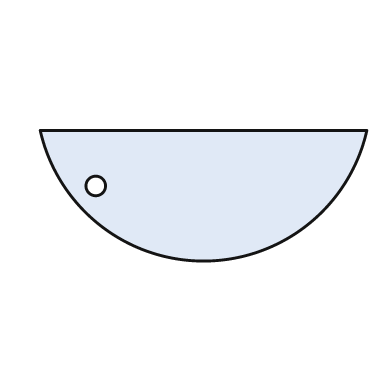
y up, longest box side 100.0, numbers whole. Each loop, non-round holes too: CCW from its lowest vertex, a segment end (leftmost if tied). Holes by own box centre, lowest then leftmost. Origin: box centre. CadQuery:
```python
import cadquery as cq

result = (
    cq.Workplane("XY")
    .moveTo(-50.0, 20.0)
    .threePointArc((0.0, -20.0), (50.0, 20.0))
    .close()
    .moveTo(-33.0, 3.0)
    .circle(3.0)
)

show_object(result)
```